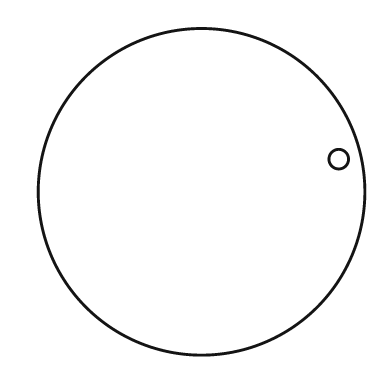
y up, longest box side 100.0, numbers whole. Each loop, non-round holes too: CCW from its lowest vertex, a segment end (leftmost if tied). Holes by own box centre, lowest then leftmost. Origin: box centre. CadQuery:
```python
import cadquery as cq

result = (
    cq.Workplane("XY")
    .moveTo(0.0, 0.0)
    .circle(50.0)
    .moveTo(42.0, 10.0)
    .circle(3.0)
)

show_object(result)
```